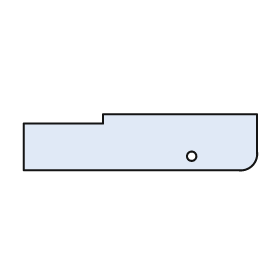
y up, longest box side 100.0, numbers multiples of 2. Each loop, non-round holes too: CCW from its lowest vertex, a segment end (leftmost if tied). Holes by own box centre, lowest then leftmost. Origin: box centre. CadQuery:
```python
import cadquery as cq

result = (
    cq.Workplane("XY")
    .moveTo(-50.0, -12.0)
    .lineTo(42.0, -12.0)
    .threePointArc((48.0, -10.0), (50.0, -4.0))
    .lineTo(50.0, 12.0)
    .lineTo(-16.0, 12.0)
    .lineTo(-16.0, 8.0)
    .lineTo(-50.0, 8.0)
    .close()
    .moveTo(22.0, -6.0)
    .circle(2.0)
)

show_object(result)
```